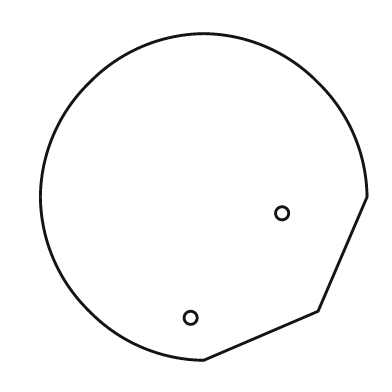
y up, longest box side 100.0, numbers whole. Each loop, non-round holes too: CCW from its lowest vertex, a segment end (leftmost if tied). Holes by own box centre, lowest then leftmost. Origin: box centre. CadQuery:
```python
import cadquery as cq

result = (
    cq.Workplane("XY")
    .moveTo(0.0, -50.0)
    .lineTo(35.0, -35.0)
    .lineTo(50.0, 0.0)
    .threePointArc((46.0, 19.0), (35.0, 35.0))
    .threePointArc((19.0, 46.0), (0.0, 50.0))
    .threePointArc((-19.0, 46.0), (-35.0, 35.0))
    .threePointArc((-46.0, 19.0), (-50.0, 0.0))
    .threePointArc((-46.0, -19.0), (-35.0, -35.0))
    .threePointArc((-19.0, -46.0), (0.0, -50.0))
    .close()
    .moveTo(-4.0, -37.0)
    .circle(2.0)
    .moveTo(24.0, -5.0)
    .circle(2.0)
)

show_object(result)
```